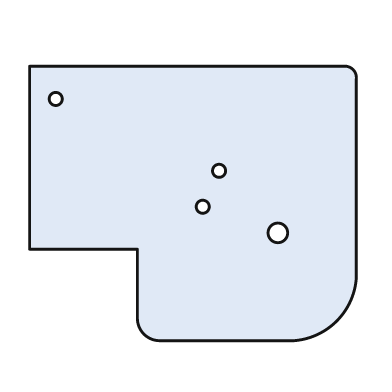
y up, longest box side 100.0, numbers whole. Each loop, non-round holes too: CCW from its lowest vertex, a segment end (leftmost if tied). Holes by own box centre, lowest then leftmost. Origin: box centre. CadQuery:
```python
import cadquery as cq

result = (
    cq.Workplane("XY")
    .moveTo(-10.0, -42.0)
    .lineTo(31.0, -42.0)
    .threePointArc((44.0, -36.0), (50.0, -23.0))
    .lineTo(50.0, 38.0)
    .threePointArc((49.0, 41.0), (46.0, 42.0))
    .lineTo(-50.0, 42.0)
    .lineTo(-50.0, -14.0)
    .lineTo(-17.0, -14.0)
    .lineTo(-17.0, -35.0)
    .threePointArc((-15.0, -40.0), (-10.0, -42.0))
    .close()
    .moveTo(26.0, -9.0)
    .circle(3.0)
    .moveTo(3.0, -1.0)
    .circle(2.0)
    .moveTo(8.0, 10.0)
    .circle(2.0)
    .moveTo(-42.0, 32.0)
    .circle(2.0)
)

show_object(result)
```